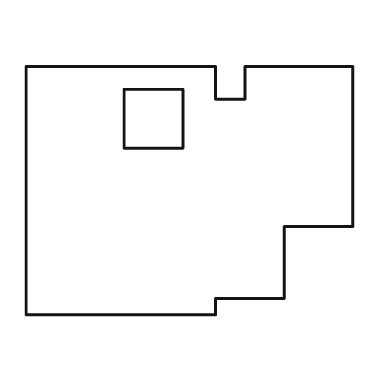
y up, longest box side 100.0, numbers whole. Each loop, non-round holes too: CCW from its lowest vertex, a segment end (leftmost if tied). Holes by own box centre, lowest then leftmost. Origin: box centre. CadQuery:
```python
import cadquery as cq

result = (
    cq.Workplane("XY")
    .moveTo(-50.0, -38.0)
    .lineTo(8.0, -38.0)
    .lineTo(8.0, -33.0)
    .lineTo(29.0, -33.0)
    .lineTo(29.0, -11.0)
    .lineTo(50.0, -11.0)
    .lineTo(50.0, 38.0)
    .lineTo(17.0, 38.0)
    .lineTo(17.0, 28.0)
    .lineTo(8.0, 28.0)
    .lineTo(8.0, 38.0)
    .lineTo(-50.0, 38.0)
    .close()
    .moveTo(-20.0, 13.0)
    .lineTo(-2.0, 13.0)
    .lineTo(-2.0, 31.0)
    .lineTo(-20.0, 31.0)
    .close()
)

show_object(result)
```